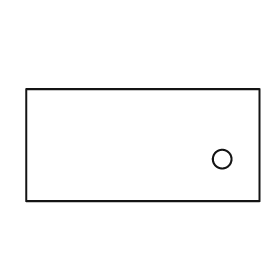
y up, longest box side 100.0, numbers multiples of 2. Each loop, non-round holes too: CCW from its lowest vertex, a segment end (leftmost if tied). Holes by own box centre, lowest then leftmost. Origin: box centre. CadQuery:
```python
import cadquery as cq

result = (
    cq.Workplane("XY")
    .moveTo(-50.0, -24.0)
    .lineTo(50.0, -24.0)
    .lineTo(50.0, 24.0)
    .lineTo(-50.0, 24.0)
    .close()
    .moveTo(34.0, -6.0)
    .circle(4.0)
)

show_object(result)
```